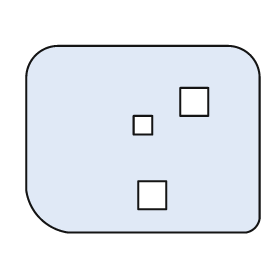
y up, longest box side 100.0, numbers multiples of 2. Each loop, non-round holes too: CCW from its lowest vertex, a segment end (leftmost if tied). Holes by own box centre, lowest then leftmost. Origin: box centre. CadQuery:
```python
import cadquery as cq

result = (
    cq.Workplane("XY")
    .moveTo(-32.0, -40.0)
    .lineTo(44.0, -40.0)
    .threePointArc((48.0, -38.0), (50.0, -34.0))
    .lineTo(50.0, 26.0)
    .threePointArc((46.0, 36.0), (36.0, 40.0))
    .lineTo(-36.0, 40.0)
    .threePointArc((-46.0, 36.0), (-50.0, 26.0))
    .lineTo(-50.0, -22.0)
    .threePointArc((-44.0, -34.0), (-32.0, -40.0))
    .close()
    .moveTo(-2.0, -30.0)
    .lineTo(10.0, -30.0)
    .lineTo(10.0, -18.0)
    .lineTo(-2.0, -18.0)
    .close()
    .moveTo(-4.0, 2.0)
    .lineTo(4.0, 2.0)
    .lineTo(4.0, 10.0)
    .lineTo(-4.0, 10.0)
    .close()
    .moveTo(16.0, 10.0)
    .lineTo(28.0, 10.0)
    .lineTo(28.0, 22.0)
    .lineTo(16.0, 22.0)
    .close()
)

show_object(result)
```